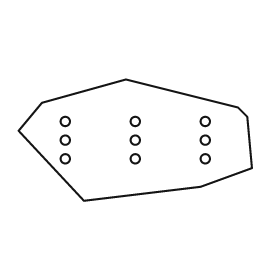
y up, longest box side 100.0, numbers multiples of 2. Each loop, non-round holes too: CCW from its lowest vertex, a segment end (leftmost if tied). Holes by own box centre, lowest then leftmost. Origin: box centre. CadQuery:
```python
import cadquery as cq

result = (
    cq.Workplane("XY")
    .moveTo(-22.0, -26.0)
    .lineTo(28.0, -20.0)
    .lineTo(50.0, -12.0)
    .lineTo(48.0, 10.0)
    .lineTo(44.0, 14.0)
    .lineTo(-4.0, 26.0)
    .lineTo(-40.0, 16.0)
    .lineTo(-50.0, 4.0)
    .close()
    .moveTo(-30.0, -8.0)
    .circle(2.0)
    .moveTo(0.0, -8.0)
    .circle(2.0)
    .moveTo(30.0, -8.0)
    .circle(2.0)
    .moveTo(-30.0, 0.0)
    .circle(2.0)
    .moveTo(0.0, 0.0)
    .circle(2.0)
    .moveTo(30.0, 0.0)
    .circle(2.0)
    .moveTo(-30.0, 8.0)
    .circle(2.0)
    .moveTo(0.0, 8.0)
    .circle(2.0)
    .moveTo(30.0, 8.0)
    .circle(2.0)
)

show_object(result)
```